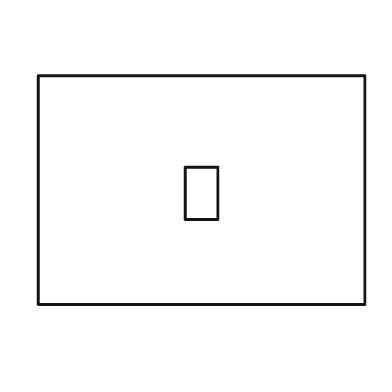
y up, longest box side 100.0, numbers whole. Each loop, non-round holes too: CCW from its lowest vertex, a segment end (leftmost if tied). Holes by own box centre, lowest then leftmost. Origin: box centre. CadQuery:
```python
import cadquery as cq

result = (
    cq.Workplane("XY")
    .moveTo(-50.0, -35.0)
    .lineTo(50.0, -35.0)
    .lineTo(50.0, 35.0)
    .lineTo(-50.0, 35.0)
    .close()
    .moveTo(-5.0, -9.0)
    .lineTo(5.0, -9.0)
    .lineTo(5.0, 7.0)
    .lineTo(-5.0, 7.0)
    .close()
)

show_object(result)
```